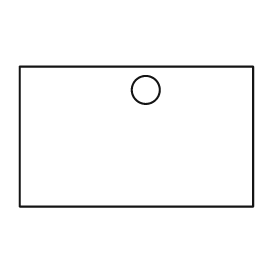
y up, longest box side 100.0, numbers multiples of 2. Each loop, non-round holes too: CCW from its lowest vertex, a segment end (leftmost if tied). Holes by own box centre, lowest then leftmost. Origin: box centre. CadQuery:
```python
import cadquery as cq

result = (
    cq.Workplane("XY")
    .moveTo(-50.0, -30.0)
    .lineTo(50.0, -30.0)
    .lineTo(50.0, 30.0)
    .lineTo(-50.0, 30.0)
    .close()
    .moveTo(4.0, 20.0)
    .circle(6.0)
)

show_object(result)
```